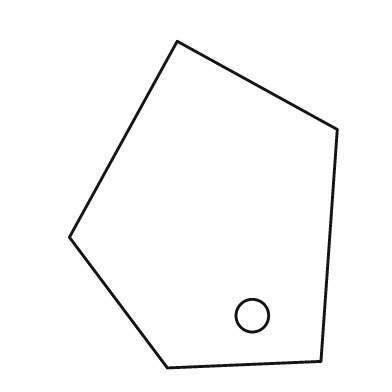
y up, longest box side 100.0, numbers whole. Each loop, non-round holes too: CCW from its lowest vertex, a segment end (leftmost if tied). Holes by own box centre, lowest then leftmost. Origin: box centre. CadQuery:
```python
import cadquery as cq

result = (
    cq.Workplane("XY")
    .moveTo(-11.0, -50.0)
    .lineTo(36.0, -48.0)
    .lineTo(41.0, 23.0)
    .lineTo(-8.0, 50.0)
    .lineTo(-41.0, -10.0)
    .close()
    .moveTo(15.0, -34.0)
    .circle(5.0)
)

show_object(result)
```